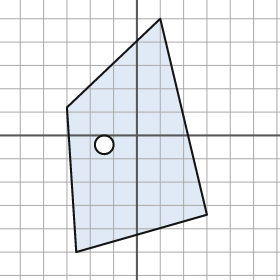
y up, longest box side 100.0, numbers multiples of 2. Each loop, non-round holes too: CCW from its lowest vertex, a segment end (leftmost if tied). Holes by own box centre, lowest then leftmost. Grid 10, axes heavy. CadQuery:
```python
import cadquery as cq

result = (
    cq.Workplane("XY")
    .moveTo(-26.0, -50.0)
    .lineTo(30.0, -34.0)
    .lineTo(10.0, 50.0)
    .lineTo(-30.0, 12.0)
    .close()
    .moveTo(-14.0, -4.0)
    .circle(4.0)
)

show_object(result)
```